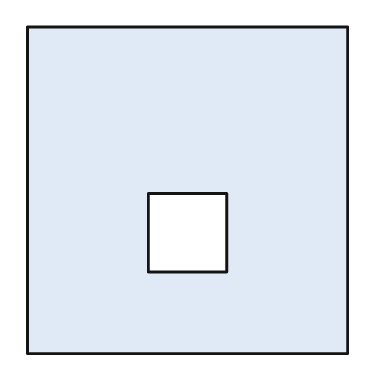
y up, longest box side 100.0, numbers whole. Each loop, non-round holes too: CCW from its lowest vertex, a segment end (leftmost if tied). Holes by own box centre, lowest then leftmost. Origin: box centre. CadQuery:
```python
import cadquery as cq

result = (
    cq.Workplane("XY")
    .moveTo(-49.0, -50.0)
    .lineTo(49.0, -50.0)
    .lineTo(49.0, 50.0)
    .lineTo(-49.0, 50.0)
    .close()
    .moveTo(-12.0, -25.0)
    .lineTo(12.0, -25.0)
    .lineTo(12.0, -1.0)
    .lineTo(-12.0, -1.0)
    .close()
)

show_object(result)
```